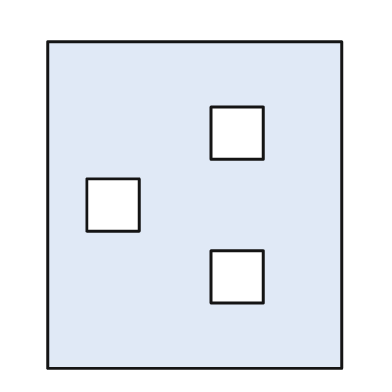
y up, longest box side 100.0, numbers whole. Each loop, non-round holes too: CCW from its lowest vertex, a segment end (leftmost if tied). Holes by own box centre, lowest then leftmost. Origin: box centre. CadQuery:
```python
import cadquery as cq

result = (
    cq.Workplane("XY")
    .moveTo(-45.0, -50.0)
    .lineTo(45.0, -50.0)
    .lineTo(45.0, 50.0)
    .lineTo(-45.0, 50.0)
    .close()
    .moveTo(5.0, -30.0)
    .lineTo(21.0, -30.0)
    .lineTo(21.0, -14.0)
    .lineTo(5.0, -14.0)
    .close()
    .moveTo(-33.0, -8.0)
    .lineTo(-17.0, -8.0)
    .lineTo(-17.0, 8.0)
    .lineTo(-33.0, 8.0)
    .close()
    .moveTo(5.0, 14.0)
    .lineTo(21.0, 14.0)
    .lineTo(21.0, 30.0)
    .lineTo(5.0, 30.0)
    .close()
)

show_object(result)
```